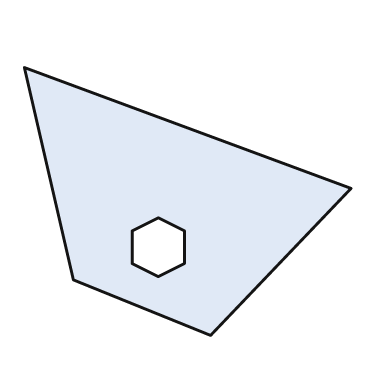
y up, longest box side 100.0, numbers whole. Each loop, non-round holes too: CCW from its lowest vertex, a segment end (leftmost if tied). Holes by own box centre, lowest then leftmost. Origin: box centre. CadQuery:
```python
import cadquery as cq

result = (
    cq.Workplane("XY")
    .moveTo(7.0, -41.0)
    .lineTo(50.0, 4.0)
    .lineTo(-50.0, 41.0)
    .lineTo(-35.0, -24.0)
    .close()
    .moveTo(-9.0, -23.0)
    .lineTo(-1.0, -19.0)
    .lineTo(-1.0, -9.0)
    .lineTo(-9.0, -5.0)
    .lineTo(-17.0, -9.0)
    .lineTo(-17.0, -19.0)
    .close()
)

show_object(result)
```